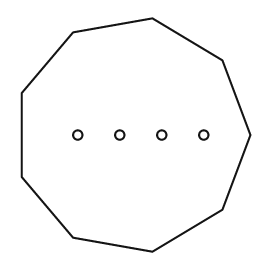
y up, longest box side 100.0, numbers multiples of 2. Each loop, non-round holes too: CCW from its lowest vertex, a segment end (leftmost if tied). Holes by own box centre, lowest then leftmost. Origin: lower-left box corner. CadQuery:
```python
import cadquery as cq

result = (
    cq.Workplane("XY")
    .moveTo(56.0, 0.0)
    .lineTo(86.0, 18.0)
    .lineTo(98.0, 50.0)
    .lineTo(86.0, 82.0)
    .lineTo(56.0, 100.0)
    .lineTo(22.0, 94.0)
    .lineTo(0.0, 68.0)
    .lineTo(0.0, 32.0)
    .lineTo(22.0, 6.0)
    .close()
    .moveTo(24.0, 50.0)
    .circle(2.0)
    .moveTo(42.0, 50.0)
    .circle(2.0)
    .moveTo(60.0, 50.0)
    .circle(2.0)
    .moveTo(78.0, 50.0)
    .circle(2.0)
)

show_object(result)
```